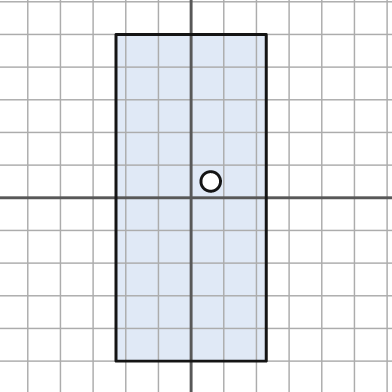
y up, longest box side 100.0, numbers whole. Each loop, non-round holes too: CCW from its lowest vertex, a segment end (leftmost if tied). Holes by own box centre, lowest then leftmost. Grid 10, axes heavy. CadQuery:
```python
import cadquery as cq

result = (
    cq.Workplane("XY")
    .moveTo(-23.0, -50.0)
    .lineTo(23.0, -50.0)
    .lineTo(23.0, 50.0)
    .lineTo(-23.0, 50.0)
    .close()
    .moveTo(6.0, 5.0)
    .circle(3.0)
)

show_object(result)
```